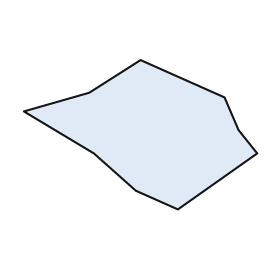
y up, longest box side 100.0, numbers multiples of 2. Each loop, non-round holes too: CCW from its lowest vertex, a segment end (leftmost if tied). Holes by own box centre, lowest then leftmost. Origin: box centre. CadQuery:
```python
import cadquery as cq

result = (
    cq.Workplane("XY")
    .moveTo(16.0, -32.0)
    .lineTo(50.0, -8.0)
    .lineTo(42.0, 2.0)
    .lineTo(36.0, 16.0)
    .lineTo(0.0, 32.0)
    .lineTo(-22.0, 18.0)
    .lineTo(-50.0, 10.0)
    .lineTo(-20.0, -8.0)
    .lineTo(-2.0, -24.0)
    .close()
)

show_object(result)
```